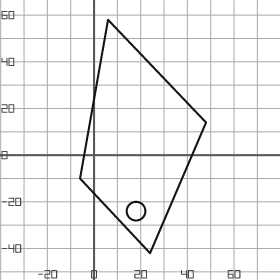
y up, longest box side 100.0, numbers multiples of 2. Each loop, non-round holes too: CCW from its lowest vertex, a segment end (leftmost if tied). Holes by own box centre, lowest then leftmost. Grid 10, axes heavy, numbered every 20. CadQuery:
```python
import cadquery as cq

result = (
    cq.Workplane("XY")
    .moveTo(24.0, -42.0)
    .lineTo(48.0, 14.0)
    .lineTo(6.0, 58.0)
    .lineTo(-6.0, -10.0)
    .close()
    .moveTo(18.0, -24.0)
    .circle(4.0)
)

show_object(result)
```